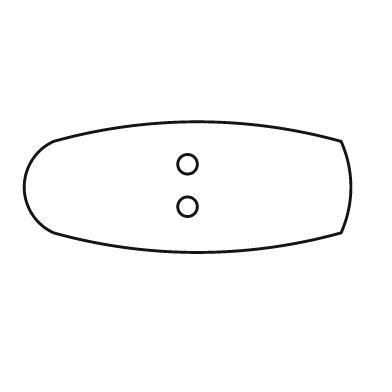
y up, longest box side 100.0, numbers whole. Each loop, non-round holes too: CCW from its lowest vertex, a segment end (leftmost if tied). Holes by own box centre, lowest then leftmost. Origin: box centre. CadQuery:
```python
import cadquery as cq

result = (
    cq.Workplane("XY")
    .moveTo(-41.0, -14.0)
    .threePointArc((3.0, -20.0), (47.0, -14.0))
    .threePointArc((50.0, 0.0), (47.0, 14.0))
    .threePointArc((3.0, 20.0), (-41.0, 14.0))
    .threePointArc((-50.0, 0.0), (-41.0, -14.0))
    .close()
    .moveTo(0.0, -6.0)
    .circle(3.0)
    .moveTo(0.0, 7.0)
    .circle(3.0)
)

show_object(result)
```